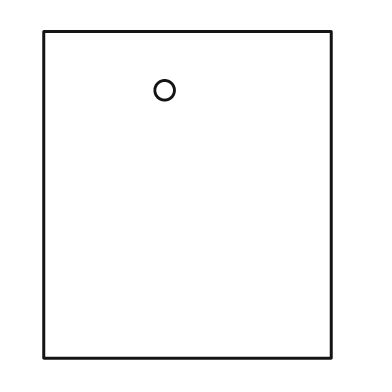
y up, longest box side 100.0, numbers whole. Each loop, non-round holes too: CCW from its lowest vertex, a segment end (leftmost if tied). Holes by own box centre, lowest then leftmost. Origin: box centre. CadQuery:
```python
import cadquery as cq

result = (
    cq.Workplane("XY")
    .moveTo(-44.0, -50.0)
    .lineTo(44.0, -50.0)
    .lineTo(44.0, 50.0)
    .lineTo(-44.0, 50.0)
    .close()
    .moveTo(-7.0, 32.0)
    .circle(3.0)
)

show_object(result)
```